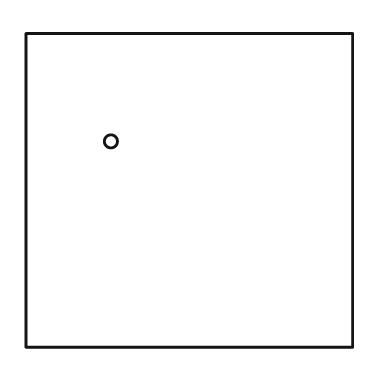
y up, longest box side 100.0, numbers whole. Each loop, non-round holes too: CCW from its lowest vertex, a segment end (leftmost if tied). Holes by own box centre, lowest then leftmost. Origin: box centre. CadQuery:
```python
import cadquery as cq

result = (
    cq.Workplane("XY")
    .moveTo(-50.0, -48.0)
    .lineTo(50.0, -48.0)
    .lineTo(50.0, 48.0)
    .lineTo(-50.0, 48.0)
    .close()
    .moveTo(-24.0, 15.0)
    .circle(2.0)
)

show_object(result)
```